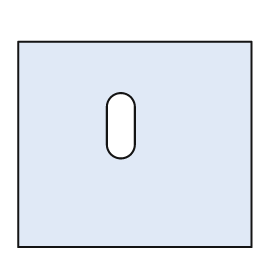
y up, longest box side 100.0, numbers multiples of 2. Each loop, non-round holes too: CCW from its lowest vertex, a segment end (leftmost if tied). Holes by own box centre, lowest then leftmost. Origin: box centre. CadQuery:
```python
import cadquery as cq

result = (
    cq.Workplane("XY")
    .moveTo(-50.0, -44.0)
    .lineTo(50.0, -44.0)
    .lineTo(50.0, 44.0)
    .lineTo(-50.0, 44.0)
    .close()
    .moveTo(-12.0, 0.0)
    .threePointArc((-6.0, -6.0), (0.0, 0.0))
    .lineTo(0.0, 16.0)
    .threePointArc((-6.0, 22.0), (-12.0, 16.0))
    .close()
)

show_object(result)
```